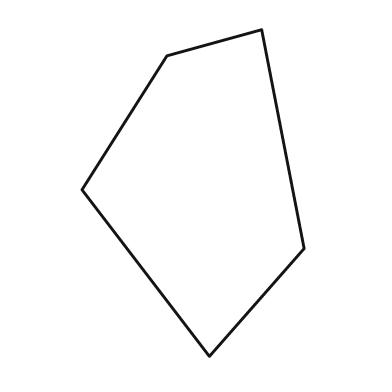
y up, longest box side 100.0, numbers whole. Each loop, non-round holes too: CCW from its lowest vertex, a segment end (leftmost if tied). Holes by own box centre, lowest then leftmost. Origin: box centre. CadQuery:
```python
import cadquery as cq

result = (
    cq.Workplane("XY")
    .moveTo(5.0, -50.0)
    .lineTo(34.0, -17.0)
    .lineTo(21.0, 50.0)
    .lineTo(-8.0, 42.0)
    .lineTo(-34.0, 1.0)
    .close()
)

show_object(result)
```